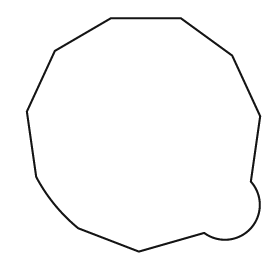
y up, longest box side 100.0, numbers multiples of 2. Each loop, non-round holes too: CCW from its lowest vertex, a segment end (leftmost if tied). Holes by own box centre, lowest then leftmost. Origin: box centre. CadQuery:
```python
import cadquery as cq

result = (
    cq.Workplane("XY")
    .moveTo(-2.0, -50.0)
    .lineTo(26.0, -42.0)
    .threePointArc((46.0, -40.0), (46.0, -20.0))
    .lineTo(50.0, 8.0)
    .lineTo(38.0, 34.0)
    .lineTo(16.0, 50.0)
    .lineTo(-14.0, 50.0)
    .lineTo(-38.0, 36.0)
    .lineTo(-50.0, 10.0)
    .lineTo(-46.0, -18.0)
    .threePointArc((-38.0, -30.0), (-28.0, -40.0))
    .close()
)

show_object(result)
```